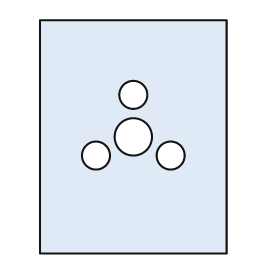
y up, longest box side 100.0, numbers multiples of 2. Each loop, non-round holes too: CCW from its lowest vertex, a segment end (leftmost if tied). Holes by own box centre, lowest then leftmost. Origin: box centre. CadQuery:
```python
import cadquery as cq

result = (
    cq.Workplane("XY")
    .moveTo(-40.0, -50.0)
    .lineTo(40.0, -50.0)
    .lineTo(40.0, 50.0)
    .lineTo(-40.0, 50.0)
    .close()
    .moveTo(-16.0, -8.0)
    .circle(6.0)
    .moveTo(16.0, -8.0)
    .circle(6.0)
    .moveTo(0.0, 0.0)
    .circle(8.0)
    .moveTo(0.0, 18.0)
    .circle(6.0)
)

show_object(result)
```